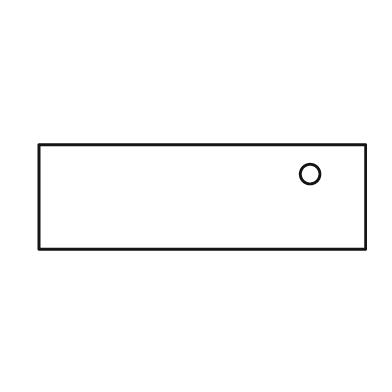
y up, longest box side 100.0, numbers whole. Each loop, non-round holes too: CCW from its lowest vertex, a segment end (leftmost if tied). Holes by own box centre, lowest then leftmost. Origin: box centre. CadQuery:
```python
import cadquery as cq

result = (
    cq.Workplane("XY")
    .moveTo(-50.0, -16.0)
    .lineTo(50.0, -16.0)
    .lineTo(50.0, 16.0)
    .lineTo(-50.0, 16.0)
    .close()
    .moveTo(33.0, 7.0)
    .circle(3.0)
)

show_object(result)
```